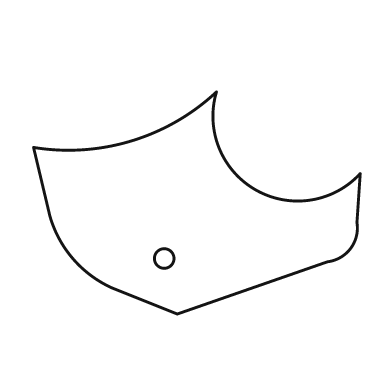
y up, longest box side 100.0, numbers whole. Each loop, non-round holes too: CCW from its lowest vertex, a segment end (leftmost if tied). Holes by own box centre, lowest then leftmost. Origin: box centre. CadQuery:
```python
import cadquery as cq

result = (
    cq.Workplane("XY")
    .moveTo(-6.0, -34.0)
    .lineTo(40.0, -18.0)
    .threePointArc((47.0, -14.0), (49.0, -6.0))
    .lineTo(50.0, 9.0)
    .threePointArc((18.0, 4.0), (6.0, 34.0))
    .threePointArc((-20.0, 19.0), (-50.0, 17.0))
    .lineTo(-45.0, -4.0)
    .threePointArc((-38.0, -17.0), (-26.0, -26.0))
    .close()
    .moveTo(-10.0, -17.0)
    .circle(3.0)
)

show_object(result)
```